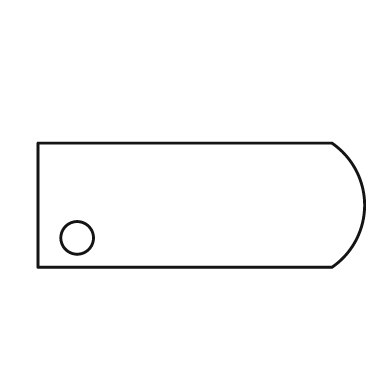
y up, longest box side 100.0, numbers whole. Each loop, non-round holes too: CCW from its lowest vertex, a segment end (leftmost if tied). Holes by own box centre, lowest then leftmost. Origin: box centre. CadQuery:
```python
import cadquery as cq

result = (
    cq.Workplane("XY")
    .moveTo(-50.0, -19.0)
    .lineTo(40.0, -19.0)
    .threePointArc((50.0, 0.0), (40.0, 19.0))
    .lineTo(-50.0, 19.0)
    .close()
    .moveTo(-38.0, -10.0)
    .circle(5.0)
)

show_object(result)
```